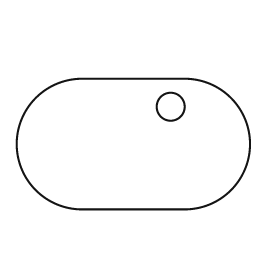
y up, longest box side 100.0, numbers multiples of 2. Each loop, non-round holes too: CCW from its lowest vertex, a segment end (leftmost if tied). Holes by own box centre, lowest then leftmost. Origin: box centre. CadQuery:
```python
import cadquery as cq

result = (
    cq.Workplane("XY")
    .moveTo(-22.0, -28.0)
    .lineTo(22.0, -28.0)
    .threePointArc((50.0, 0.0), (22.0, 28.0))
    .lineTo(-22.0, 28.0)
    .threePointArc((-50.0, 0.0), (-22.0, -28.0))
    .close()
    .moveTo(16.0, 16.0)
    .circle(6.0)
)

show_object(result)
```